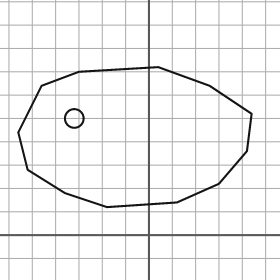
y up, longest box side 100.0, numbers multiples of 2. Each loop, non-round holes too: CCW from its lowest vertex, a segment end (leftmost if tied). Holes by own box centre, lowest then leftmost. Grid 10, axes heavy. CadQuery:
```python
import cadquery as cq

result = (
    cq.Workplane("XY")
    .moveTo(-18.0, 12.0)
    .lineTo(12.0, 14.0)
    .lineTo(30.0, 22.0)
    .lineTo(42.0, 36.0)
    .lineTo(44.0, 52.0)
    .lineTo(26.0, 64.0)
    .lineTo(4.0, 72.0)
    .lineTo(-30.0, 70.0)
    .lineTo(-46.0, 64.0)
    .lineTo(-56.0, 44.0)
    .lineTo(-52.0, 28.0)
    .lineTo(-36.0, 18.0)
    .close()
    .moveTo(-32.0, 50.0)
    .circle(4.0)
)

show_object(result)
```